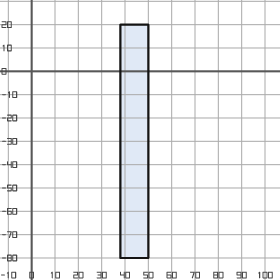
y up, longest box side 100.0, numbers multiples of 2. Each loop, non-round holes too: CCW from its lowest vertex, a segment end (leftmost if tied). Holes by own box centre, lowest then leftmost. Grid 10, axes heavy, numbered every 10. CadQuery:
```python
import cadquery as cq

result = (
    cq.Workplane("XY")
    .moveTo(38.0, -80.0)
    .lineTo(50.0, -80.0)
    .lineTo(50.0, 20.0)
    .lineTo(38.0, 20.0)
    .close()
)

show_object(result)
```